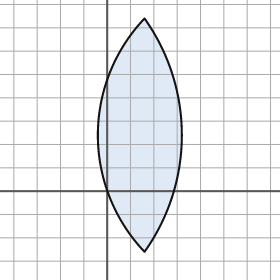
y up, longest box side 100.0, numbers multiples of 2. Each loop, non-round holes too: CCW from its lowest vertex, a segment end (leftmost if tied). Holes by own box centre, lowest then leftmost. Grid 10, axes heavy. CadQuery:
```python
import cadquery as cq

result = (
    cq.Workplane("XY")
    .moveTo(16.0, -26.0)
    .threePointArc((32.0, 24.0), (16.0, 74.0))
    .threePointArc((-4.0, 24.0), (16.0, -26.0))
    .close()
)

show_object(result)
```